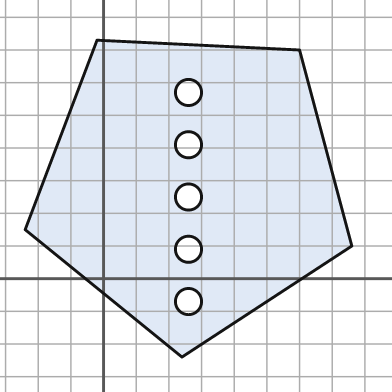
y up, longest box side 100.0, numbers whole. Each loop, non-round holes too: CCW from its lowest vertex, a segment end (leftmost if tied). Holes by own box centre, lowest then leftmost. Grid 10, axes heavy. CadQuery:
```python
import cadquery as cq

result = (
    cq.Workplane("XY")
    .moveTo(24.0, -24.0)
    .lineTo(76.0, 10.0)
    .lineTo(60.0, 70.0)
    .lineTo(-2.0, 73.0)
    .lineTo(-24.0, 15.0)
    .close()
    .moveTo(26.0, -7.0)
    .circle(4.0)
    .moveTo(26.0, 9.0)
    .circle(4.0)
    .moveTo(26.0, 25.0)
    .circle(4.0)
    .moveTo(26.0, 41.0)
    .circle(4.0)
    .moveTo(26.0, 57.0)
    .circle(4.0)
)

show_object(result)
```